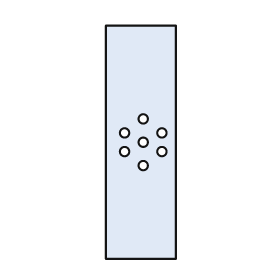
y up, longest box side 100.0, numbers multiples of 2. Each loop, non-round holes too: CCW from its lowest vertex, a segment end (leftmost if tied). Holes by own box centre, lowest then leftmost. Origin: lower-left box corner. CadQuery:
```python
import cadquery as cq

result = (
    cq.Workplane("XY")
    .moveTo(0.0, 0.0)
    .lineTo(30.0, 0.0)
    .lineTo(30.0, 100.0)
    .lineTo(0.0, 100.0)
    .close()
    .moveTo(16.0, 40.0)
    .circle(2.0)
    .moveTo(8.0, 46.0)
    .circle(2.0)
    .moveTo(24.0, 46.0)
    .circle(2.0)
    .moveTo(16.0, 50.0)
    .circle(2.0)
    .moveTo(8.0, 54.0)
    .circle(2.0)
    .moveTo(24.0, 54.0)
    .circle(2.0)
    .moveTo(16.0, 60.0)
    .circle(2.0)
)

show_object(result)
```